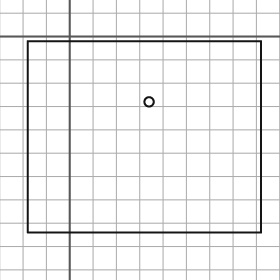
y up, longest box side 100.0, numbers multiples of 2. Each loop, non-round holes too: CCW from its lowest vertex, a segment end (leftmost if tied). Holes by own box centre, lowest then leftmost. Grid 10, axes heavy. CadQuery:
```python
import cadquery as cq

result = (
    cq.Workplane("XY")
    .moveTo(-18.0, -84.0)
    .lineTo(82.0, -84.0)
    .lineTo(82.0, -2.0)
    .lineTo(-18.0, -2.0)
    .close()
    .moveTo(34.0, -28.0)
    .circle(2.0)
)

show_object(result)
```